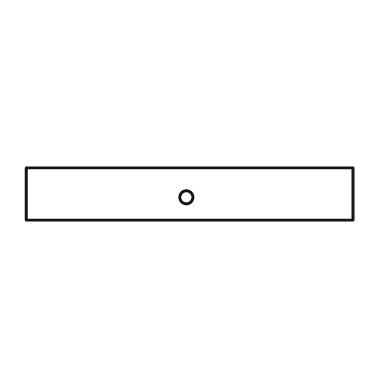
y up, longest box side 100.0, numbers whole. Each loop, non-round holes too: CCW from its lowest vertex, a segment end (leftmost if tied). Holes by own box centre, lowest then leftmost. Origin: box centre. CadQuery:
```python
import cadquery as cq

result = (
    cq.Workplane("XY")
    .moveTo(-50.0, -8.0)
    .lineTo(50.0, -8.0)
    .lineTo(50.0, 8.0)
    .lineTo(-50.0, 8.0)
    .close()
    .moveTo(-1.0, -1.0)
    .circle(2.0)
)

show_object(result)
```